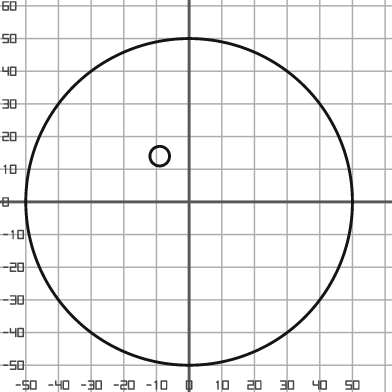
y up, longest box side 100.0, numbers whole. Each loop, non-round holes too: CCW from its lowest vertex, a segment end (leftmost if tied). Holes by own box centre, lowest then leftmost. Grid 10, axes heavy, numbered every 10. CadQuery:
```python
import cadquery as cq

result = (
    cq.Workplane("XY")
    .moveTo(0.0, 0.0)
    .circle(50.0)
    .moveTo(-9.0, 14.0)
    .circle(3.0)
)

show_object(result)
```